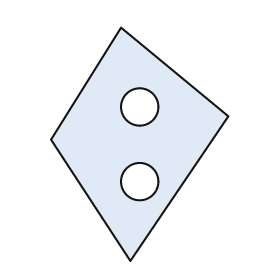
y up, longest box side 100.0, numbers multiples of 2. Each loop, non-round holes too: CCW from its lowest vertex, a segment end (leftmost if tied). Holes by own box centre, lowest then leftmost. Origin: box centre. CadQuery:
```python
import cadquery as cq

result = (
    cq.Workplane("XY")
    .moveTo(-4.0, -50.0)
    .lineTo(38.0, 12.0)
    .lineTo(-8.0, 50.0)
    .lineTo(-38.0, 2.0)
    .close()
    .moveTo(0.0, -16.0)
    .circle(8.0)
    .moveTo(0.0, 16.0)
    .circle(8.0)
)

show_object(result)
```